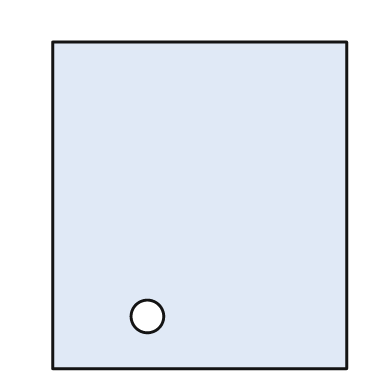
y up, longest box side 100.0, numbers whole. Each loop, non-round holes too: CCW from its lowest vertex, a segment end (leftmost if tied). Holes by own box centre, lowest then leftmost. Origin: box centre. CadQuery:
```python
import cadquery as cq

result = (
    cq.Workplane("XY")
    .moveTo(-45.0, -50.0)
    .lineTo(45.0, -50.0)
    .lineTo(45.0, 50.0)
    .lineTo(-45.0, 50.0)
    .close()
    .moveTo(-16.0, -34.0)
    .circle(5.0)
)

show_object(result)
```